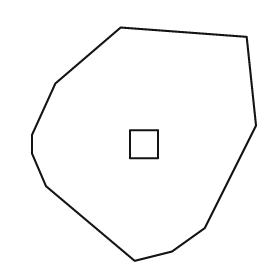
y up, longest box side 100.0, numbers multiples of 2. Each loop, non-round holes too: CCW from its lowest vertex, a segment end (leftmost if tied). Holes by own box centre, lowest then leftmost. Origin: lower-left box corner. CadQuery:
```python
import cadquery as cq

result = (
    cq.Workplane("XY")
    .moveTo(44.0, 0.0)
    .lineTo(60.0, 4.0)
    .lineTo(74.0, 14.0)
    .lineTo(96.0, 58.0)
    .lineTo(92.0, 96.0)
    .lineTo(38.0, 100.0)
    .lineTo(10.0, 76.0)
    .lineTo(0.0, 54.0)
    .lineTo(0.0, 46.0)
    .lineTo(6.0, 32.0)
    .close()
    .moveTo(42.0, 44.0)
    .lineTo(54.0, 44.0)
    .lineTo(54.0, 56.0)
    .lineTo(42.0, 56.0)
    .close()
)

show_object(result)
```